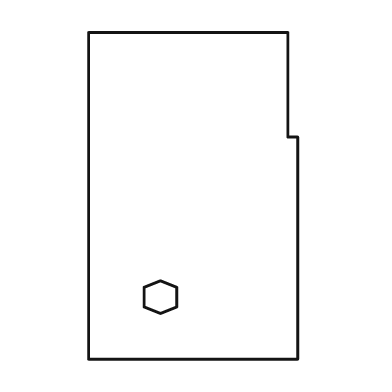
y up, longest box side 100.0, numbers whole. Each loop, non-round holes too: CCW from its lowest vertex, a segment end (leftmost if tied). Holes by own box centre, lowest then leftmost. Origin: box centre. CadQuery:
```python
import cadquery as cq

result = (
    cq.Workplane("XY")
    .moveTo(-32.0, -50.0)
    .lineTo(32.0, -50.0)
    .lineTo(32.0, 18.0)
    .lineTo(29.0, 18.0)
    .lineTo(29.0, 50.0)
    .lineTo(-32.0, 50.0)
    .close()
    .moveTo(-10.0, -36.0)
    .lineTo(-5.0, -34.0)
    .lineTo(-5.0, -28.0)
    .lineTo(-10.0, -26.0)
    .lineTo(-15.0, -28.0)
    .lineTo(-15.0, -34.0)
    .close()
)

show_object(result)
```